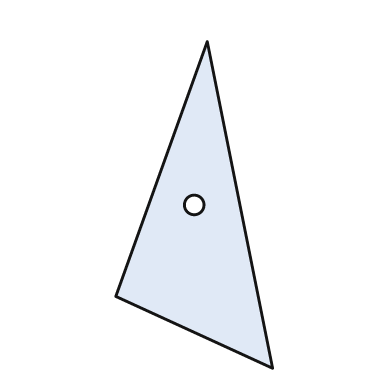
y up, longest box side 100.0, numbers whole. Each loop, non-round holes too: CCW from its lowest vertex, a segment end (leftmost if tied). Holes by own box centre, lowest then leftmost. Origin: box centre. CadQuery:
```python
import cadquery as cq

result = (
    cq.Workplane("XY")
    .moveTo(24.0, -50.0)
    .lineTo(4.0, 50.0)
    .lineTo(-24.0, -28.0)
    .close()
    .moveTo(0.0, 0.0)
    .circle(3.0)
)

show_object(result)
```